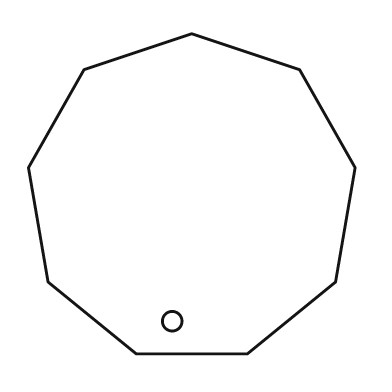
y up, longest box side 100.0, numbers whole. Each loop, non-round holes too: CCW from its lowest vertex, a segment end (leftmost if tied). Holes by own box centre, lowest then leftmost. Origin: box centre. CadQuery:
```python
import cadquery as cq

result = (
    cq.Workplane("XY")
    .moveTo(-17.0, -49.0)
    .lineTo(17.0, -49.0)
    .lineTo(44.0, -27.0)
    .lineTo(50.0, 8.0)
    .lineTo(33.0, 38.0)
    .lineTo(0.0, 49.0)
    .lineTo(-33.0, 38.0)
    .lineTo(-50.0, 8.0)
    .lineTo(-44.0, -27.0)
    .close()
    .moveTo(-6.0, -39.0)
    .circle(3.0)
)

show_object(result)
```